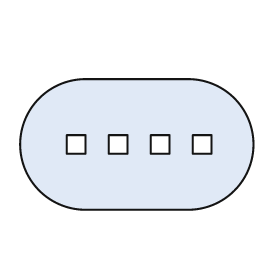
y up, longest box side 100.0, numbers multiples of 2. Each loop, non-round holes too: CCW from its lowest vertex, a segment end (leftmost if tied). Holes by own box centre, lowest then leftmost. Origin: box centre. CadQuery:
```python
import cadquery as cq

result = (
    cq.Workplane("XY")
    .moveTo(-22.0, -28.0)
    .lineTo(22.0, -28.0)
    .threePointArc((50.0, 0.0), (22.0, 28.0))
    .lineTo(-22.0, 28.0)
    .threePointArc((-50.0, 0.0), (-22.0, -28.0))
    .close()
    .moveTo(-30.0, -4.0)
    .lineTo(-22.0, -4.0)
    .lineTo(-22.0, 4.0)
    .lineTo(-30.0, 4.0)
    .close()
    .moveTo(-12.0, -4.0)
    .lineTo(-4.0, -4.0)
    .lineTo(-4.0, 4.0)
    .lineTo(-12.0, 4.0)
    .close()
    .moveTo(6.0, -4.0)
    .lineTo(14.0, -4.0)
    .lineTo(14.0, 4.0)
    .lineTo(6.0, 4.0)
    .close()
    .moveTo(24.0, -4.0)
    .lineTo(32.0, -4.0)
    .lineTo(32.0, 4.0)
    .lineTo(24.0, 4.0)
    .close()
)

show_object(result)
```